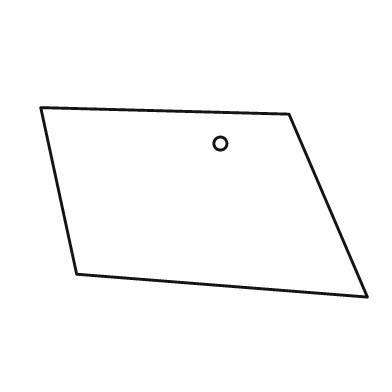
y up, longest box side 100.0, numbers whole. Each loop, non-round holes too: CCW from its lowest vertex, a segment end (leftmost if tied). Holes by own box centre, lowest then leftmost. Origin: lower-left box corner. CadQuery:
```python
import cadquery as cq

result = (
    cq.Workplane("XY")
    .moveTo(100.0, 0.0)
    .lineTo(76.0, 56.0)
    .lineTo(0.0, 58.0)
    .lineTo(11.0, 7.0)
    .close()
    .moveTo(55.0, 47.0)
    .circle(2.0)
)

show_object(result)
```